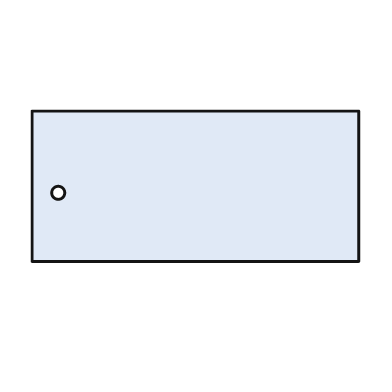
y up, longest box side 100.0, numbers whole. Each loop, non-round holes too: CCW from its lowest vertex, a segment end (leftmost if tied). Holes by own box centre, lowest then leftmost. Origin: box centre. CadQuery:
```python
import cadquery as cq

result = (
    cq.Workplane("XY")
    .moveTo(-50.0, -23.0)
    .lineTo(50.0, -23.0)
    .lineTo(50.0, 23.0)
    .lineTo(-50.0, 23.0)
    .close()
    .moveTo(-42.0, -2.0)
    .circle(2.0)
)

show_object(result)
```